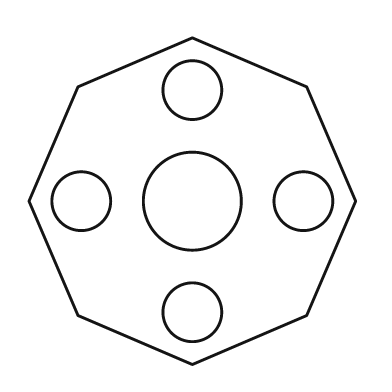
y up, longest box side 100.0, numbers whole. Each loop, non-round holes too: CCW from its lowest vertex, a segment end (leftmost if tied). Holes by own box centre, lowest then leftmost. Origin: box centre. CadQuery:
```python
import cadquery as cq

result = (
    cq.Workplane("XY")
    .moveTo(0.0, -50.0)
    .lineTo(35.0, -35.0)
    .lineTo(50.0, 0.0)
    .lineTo(35.0, 35.0)
    .lineTo(0.0, 50.0)
    .lineTo(-35.0, 35.0)
    .lineTo(-50.0, 0.0)
    .lineTo(-35.0, -35.0)
    .close()
    .moveTo(0.0, -34.0)
    .circle(9.0)
    .moveTo(-34.0, 0.0)
    .circle(9.0)
    .moveTo(0.0, 0.0)
    .circle(15.0)
    .moveTo(34.0, 0.0)
    .circle(9.0)
    .moveTo(0.0, 34.0)
    .circle(9.0)
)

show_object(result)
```